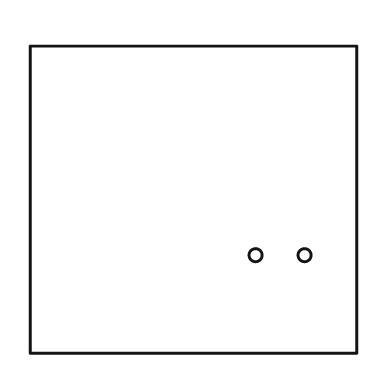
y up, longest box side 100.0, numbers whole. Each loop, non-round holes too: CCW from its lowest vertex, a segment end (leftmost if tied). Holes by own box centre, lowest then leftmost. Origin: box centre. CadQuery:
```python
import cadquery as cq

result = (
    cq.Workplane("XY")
    .moveTo(-50.0, -47.0)
    .lineTo(50.0, -47.0)
    .lineTo(50.0, 47.0)
    .lineTo(-50.0, 47.0)
    .close()
    .moveTo(19.0, -17.0)
    .circle(2.0)
    .moveTo(34.0, -17.0)
    .circle(2.0)
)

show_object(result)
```